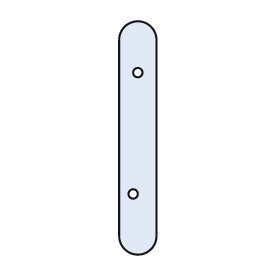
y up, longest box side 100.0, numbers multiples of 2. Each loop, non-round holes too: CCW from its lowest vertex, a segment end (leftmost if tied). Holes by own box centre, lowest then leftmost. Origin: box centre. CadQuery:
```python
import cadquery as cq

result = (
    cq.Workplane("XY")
    .moveTo(-8.0, -42.0)
    .threePointArc((0.0, -50.0), (8.0, -42.0))
    .lineTo(8.0, 42.0)
    .threePointArc((0.0, 50.0), (-8.0, 42.0))
    .close()
    .moveTo(-2.0, -24.0)
    .circle(2.0)
    .moveTo(0.0, 28.0)
    .circle(2.0)
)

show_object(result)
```